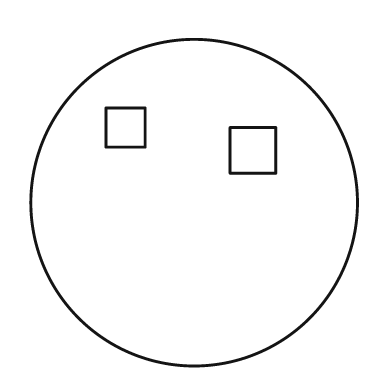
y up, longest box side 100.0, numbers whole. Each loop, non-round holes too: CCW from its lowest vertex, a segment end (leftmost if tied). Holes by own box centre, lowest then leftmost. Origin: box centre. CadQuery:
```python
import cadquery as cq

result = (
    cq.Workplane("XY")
    .moveTo(0.0, 0.0)
    .circle(50.0)
    .moveTo(11.0, 9.0)
    .lineTo(25.0, 9.0)
    .lineTo(25.0, 23.0)
    .lineTo(11.0, 23.0)
    .close()
    .moveTo(-27.0, 17.0)
    .lineTo(-15.0, 17.0)
    .lineTo(-15.0, 29.0)
    .lineTo(-27.0, 29.0)
    .close()
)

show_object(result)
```